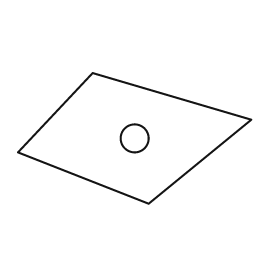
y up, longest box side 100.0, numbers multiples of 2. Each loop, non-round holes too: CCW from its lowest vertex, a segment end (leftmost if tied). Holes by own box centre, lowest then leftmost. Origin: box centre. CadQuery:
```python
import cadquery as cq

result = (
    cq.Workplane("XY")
    .moveTo(6.0, -28.0)
    .lineTo(50.0, 8.0)
    .lineTo(-18.0, 28.0)
    .lineTo(-50.0, -6.0)
    .close()
    .moveTo(0.0, 0.0)
    .circle(6.0)
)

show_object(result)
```